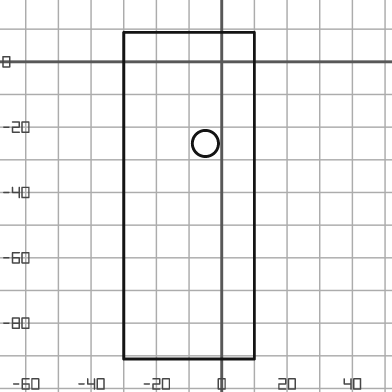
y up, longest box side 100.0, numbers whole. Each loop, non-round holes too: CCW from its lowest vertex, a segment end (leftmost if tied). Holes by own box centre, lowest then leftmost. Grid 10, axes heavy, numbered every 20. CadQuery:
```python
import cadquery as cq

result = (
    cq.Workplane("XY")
    .moveTo(-30.0, -91.0)
    .lineTo(10.0, -91.0)
    .lineTo(10.0, 9.0)
    .lineTo(-30.0, 9.0)
    .close()
    .moveTo(-5.0, -25.0)
    .circle(4.0)
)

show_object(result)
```